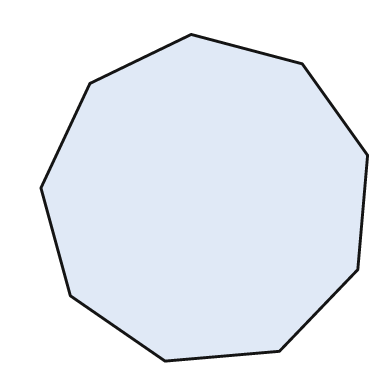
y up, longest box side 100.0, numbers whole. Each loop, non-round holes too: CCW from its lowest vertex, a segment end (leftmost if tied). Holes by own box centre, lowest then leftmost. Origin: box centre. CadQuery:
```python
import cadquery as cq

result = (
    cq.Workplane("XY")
    .moveTo(-12.0, -50.0)
    .lineTo(23.0, -47.0)
    .lineTo(47.0, -22.0)
    .lineTo(50.0, 13.0)
    .lineTo(30.0, 41.0)
    .lineTo(-4.0, 50.0)
    .lineTo(-35.0, 35.0)
    .lineTo(-50.0, 3.0)
    .lineTo(-41.0, -30.0)
    .close()
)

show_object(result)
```